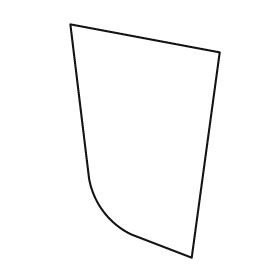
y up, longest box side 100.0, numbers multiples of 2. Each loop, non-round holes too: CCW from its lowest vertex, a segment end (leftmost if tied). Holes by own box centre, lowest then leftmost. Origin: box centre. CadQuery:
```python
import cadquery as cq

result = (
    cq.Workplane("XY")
    .moveTo(20.0, -50.0)
    .lineTo(32.0, 38.0)
    .lineTo(-32.0, 50.0)
    .lineTo(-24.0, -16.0)
    .threePointArc((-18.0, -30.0), (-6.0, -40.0))
    .close()
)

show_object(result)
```